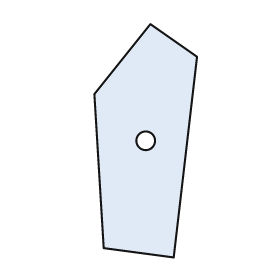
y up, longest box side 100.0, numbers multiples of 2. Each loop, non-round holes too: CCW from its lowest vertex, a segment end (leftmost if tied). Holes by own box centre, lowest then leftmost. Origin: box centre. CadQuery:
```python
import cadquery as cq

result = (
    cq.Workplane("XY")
    .moveTo(12.0, -50.0)
    .lineTo(22.0, 36.0)
    .lineTo(2.0, 50.0)
    .lineTo(-22.0, 20.0)
    .lineTo(-18.0, -46.0)
    .close()
    .moveTo(0.0, 0.0)
    .circle(4.0)
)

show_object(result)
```